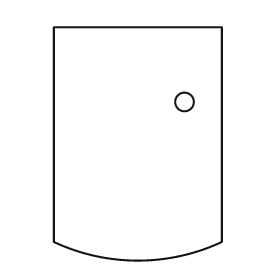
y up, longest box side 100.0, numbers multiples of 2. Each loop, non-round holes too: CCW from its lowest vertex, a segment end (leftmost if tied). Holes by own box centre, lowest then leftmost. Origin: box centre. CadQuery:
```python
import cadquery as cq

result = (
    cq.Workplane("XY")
    .moveTo(-36.0, -42.0)
    .threePointArc((0.0, -50.0), (36.0, -42.0))
    .lineTo(36.0, 50.0)
    .lineTo(-36.0, 50.0)
    .close()
    .moveTo(20.0, 18.0)
    .circle(4.0)
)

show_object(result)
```